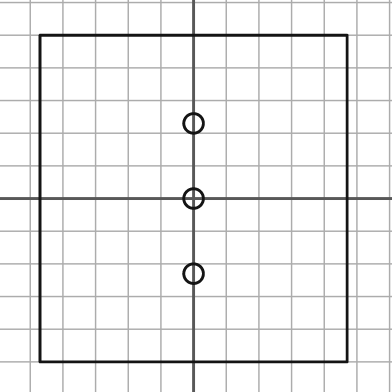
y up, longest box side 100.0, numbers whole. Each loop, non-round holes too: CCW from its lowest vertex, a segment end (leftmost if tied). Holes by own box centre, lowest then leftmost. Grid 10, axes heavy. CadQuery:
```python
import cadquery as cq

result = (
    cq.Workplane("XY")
    .moveTo(-47.0, -50.0)
    .lineTo(47.0, -50.0)
    .lineTo(47.0, 50.0)
    .lineTo(-47.0, 50.0)
    .close()
    .moveTo(0.0, -23.0)
    .circle(3.0)
    .moveTo(0.0, 0.0)
    .circle(3.0)
    .moveTo(0.0, 23.0)
    .circle(3.0)
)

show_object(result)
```